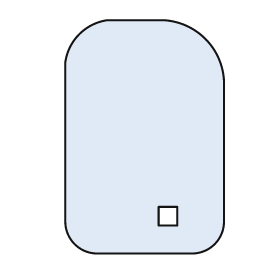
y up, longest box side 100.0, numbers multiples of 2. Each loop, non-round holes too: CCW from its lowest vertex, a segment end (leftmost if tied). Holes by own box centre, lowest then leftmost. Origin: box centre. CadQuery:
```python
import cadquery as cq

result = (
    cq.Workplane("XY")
    .moveTo(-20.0, -50.0)
    .lineTo(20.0, -50.0)
    .threePointArc((30.0, -46.0), (34.0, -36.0))
    .lineTo(34.0, 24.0)
    .threePointArc((26.0, 42.0), (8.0, 50.0))
    .lineTo(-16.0, 50.0)
    .threePointArc((-28.0, 44.0), (-34.0, 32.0))
    .lineTo(-34.0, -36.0)
    .threePointArc((-30.0, -46.0), (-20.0, -50.0))
    .close()
    .moveTo(6.0, -38.0)
    .lineTo(14.0, -38.0)
    .lineTo(14.0, -30.0)
    .lineTo(6.0, -30.0)
    .close()
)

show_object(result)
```